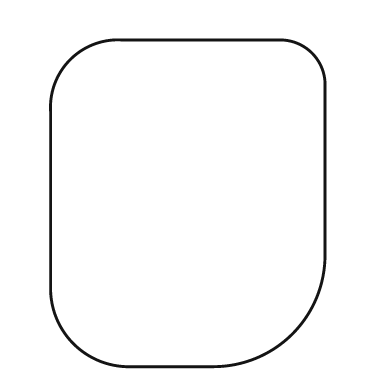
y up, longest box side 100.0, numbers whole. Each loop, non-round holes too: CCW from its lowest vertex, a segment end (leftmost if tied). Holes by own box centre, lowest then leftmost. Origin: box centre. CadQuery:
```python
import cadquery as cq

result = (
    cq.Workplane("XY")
    .moveTo(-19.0, -50.0)
    .lineTo(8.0, -50.0)
    .threePointArc((32.0, -40.0), (42.0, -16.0))
    .lineTo(42.0, 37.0)
    .threePointArc((38.0, 46.0), (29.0, 50.0))
    .lineTo(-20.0, 50.0)
    .threePointArc((-36.0, 44.0), (-42.0, 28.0))
    .lineTo(-42.0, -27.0)
    .threePointArc((-35.0, -43.0), (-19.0, -50.0))
    .close()
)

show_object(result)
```